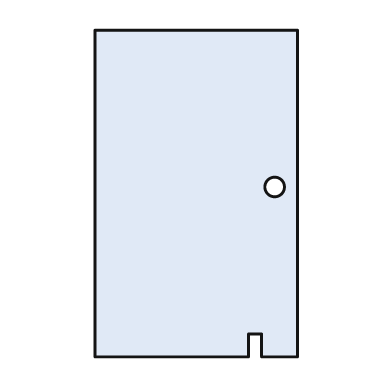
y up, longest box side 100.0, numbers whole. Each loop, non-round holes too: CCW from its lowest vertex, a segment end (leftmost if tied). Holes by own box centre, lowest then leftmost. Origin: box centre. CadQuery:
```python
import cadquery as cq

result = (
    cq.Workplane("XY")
    .moveTo(-31.0, -50.0)
    .lineTo(16.0, -50.0)
    .lineTo(16.0, -43.0)
    .lineTo(20.0, -43.0)
    .lineTo(20.0, -50.0)
    .lineTo(31.0, -50.0)
    .lineTo(31.0, 50.0)
    .lineTo(-31.0, 50.0)
    .close()
    .moveTo(24.0, 2.0)
    .circle(3.0)
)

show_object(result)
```